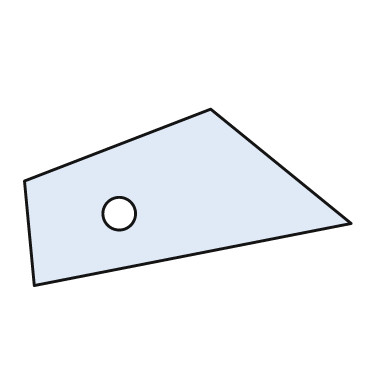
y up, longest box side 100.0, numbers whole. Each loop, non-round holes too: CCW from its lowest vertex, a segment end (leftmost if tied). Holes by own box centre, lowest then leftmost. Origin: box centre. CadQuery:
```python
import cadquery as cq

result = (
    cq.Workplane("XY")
    .moveTo(-47.0, -27.0)
    .lineTo(50.0, -8.0)
    .lineTo(7.0, 27.0)
    .lineTo(-50.0, 5.0)
    .close()
    .moveTo(-21.0, -5.0)
    .circle(5.0)
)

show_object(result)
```